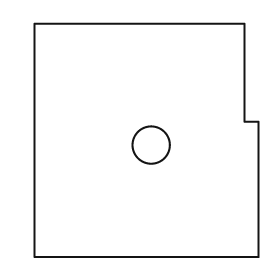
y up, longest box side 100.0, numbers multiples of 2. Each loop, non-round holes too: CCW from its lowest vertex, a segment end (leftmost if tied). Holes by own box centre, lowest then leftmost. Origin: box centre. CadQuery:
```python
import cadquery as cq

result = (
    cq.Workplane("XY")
    .moveTo(-48.0, -50.0)
    .lineTo(48.0, -50.0)
    .lineTo(48.0, 8.0)
    .lineTo(42.0, 8.0)
    .lineTo(42.0, 50.0)
    .lineTo(-48.0, 50.0)
    .close()
    .moveTo(2.0, -2.0)
    .circle(8.0)
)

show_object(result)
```